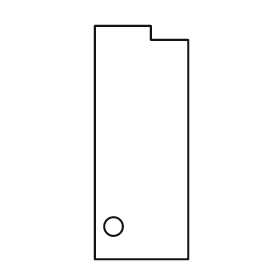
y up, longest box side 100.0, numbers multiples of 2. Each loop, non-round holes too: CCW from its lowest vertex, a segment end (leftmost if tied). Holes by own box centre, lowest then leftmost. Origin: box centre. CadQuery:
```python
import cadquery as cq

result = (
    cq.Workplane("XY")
    .moveTo(-20.0, -50.0)
    .lineTo(20.0, -50.0)
    .lineTo(20.0, 44.0)
    .lineTo(4.0, 44.0)
    .lineTo(4.0, 50.0)
    .lineTo(-20.0, 50.0)
    .close()
    .moveTo(-12.0, -36.0)
    .circle(4.0)
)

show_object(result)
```